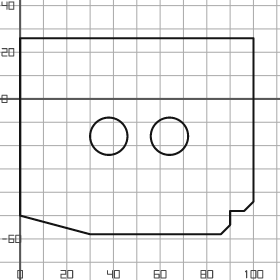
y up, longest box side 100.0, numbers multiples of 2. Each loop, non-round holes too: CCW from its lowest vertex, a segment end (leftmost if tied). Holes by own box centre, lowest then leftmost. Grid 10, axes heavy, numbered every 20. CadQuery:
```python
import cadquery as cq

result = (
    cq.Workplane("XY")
    .moveTo(30.0, -58.0)
    .lineTo(86.0, -58.0)
    .lineTo(90.0, -54.0)
    .lineTo(90.0, -48.0)
    .lineTo(96.0, -48.0)
    .lineTo(100.0, -44.0)
    .lineTo(100.0, 26.0)
    .lineTo(0.0, 26.0)
    .lineTo(0.0, -50.0)
    .close()
    .moveTo(38.0, -16.0)
    .circle(8.0)
    .moveTo(64.0, -16.0)
    .circle(8.0)
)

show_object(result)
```